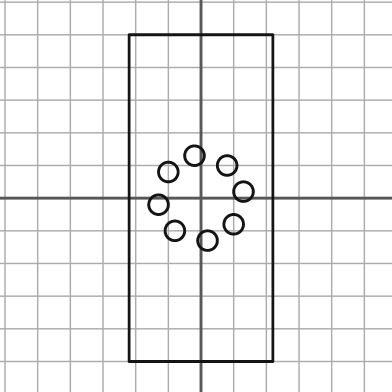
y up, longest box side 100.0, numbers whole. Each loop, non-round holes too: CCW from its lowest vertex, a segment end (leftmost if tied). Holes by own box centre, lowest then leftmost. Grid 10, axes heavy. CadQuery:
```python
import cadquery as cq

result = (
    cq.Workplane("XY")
    .moveTo(-22.0, -50.0)
    .lineTo(22.0, -50.0)
    .lineTo(22.0, 50.0)
    .lineTo(-22.0, 50.0)
    .close()
    .moveTo(2.0, -13.0)
    .circle(3.0)
    .moveTo(-8.0, -10.0)
    .circle(3.0)
    .moveTo(10.0, -8.0)
    .circle(3.0)
    .moveTo(-13.0, -2.0)
    .circle(3.0)
    .moveTo(13.0, 2.0)
    .circle(3.0)
    .moveTo(-10.0, 8.0)
    .circle(3.0)
    .moveTo(8.0, 10.0)
    .circle(3.0)
    .moveTo(-2.0, 13.0)
    .circle(3.0)
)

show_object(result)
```